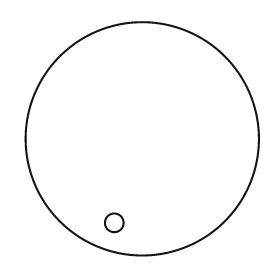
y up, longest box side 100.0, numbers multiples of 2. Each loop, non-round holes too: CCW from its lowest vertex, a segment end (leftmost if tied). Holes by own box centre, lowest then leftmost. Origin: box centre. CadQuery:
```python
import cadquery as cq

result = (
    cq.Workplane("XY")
    .moveTo(0.0, 0.0)
    .circle(50.0)
    .moveTo(-12.0, -36.0)
    .circle(4.0)
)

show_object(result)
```